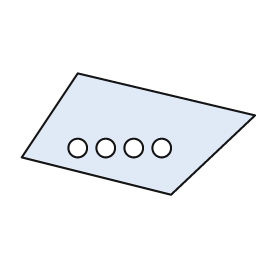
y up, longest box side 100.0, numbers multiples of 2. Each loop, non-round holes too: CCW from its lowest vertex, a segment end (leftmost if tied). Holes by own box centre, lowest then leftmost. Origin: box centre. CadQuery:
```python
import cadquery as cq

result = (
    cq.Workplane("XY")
    .moveTo(14.0, -26.0)
    .lineTo(50.0, 8.0)
    .lineTo(-26.0, 26.0)
    .lineTo(-50.0, -10.0)
    .close()
    .moveTo(-26.0, -6.0)
    .circle(4.0)
    .moveTo(-14.0, -6.0)
    .circle(4.0)
    .moveTo(-2.0, -6.0)
    .circle(4.0)
    .moveTo(10.0, -6.0)
    .circle(4.0)
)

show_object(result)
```